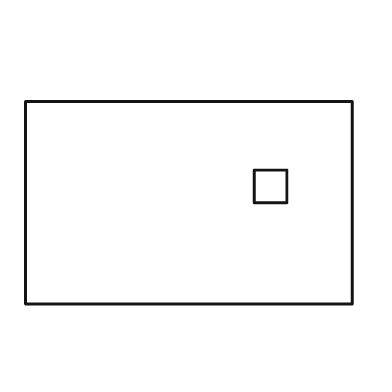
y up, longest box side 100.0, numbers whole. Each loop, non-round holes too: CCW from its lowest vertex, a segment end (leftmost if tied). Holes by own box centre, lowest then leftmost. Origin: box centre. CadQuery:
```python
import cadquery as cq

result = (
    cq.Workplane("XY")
    .moveTo(-50.0, -31.0)
    .lineTo(50.0, -31.0)
    .lineTo(50.0, 31.0)
    .lineTo(-50.0, 31.0)
    .close()
    .moveTo(20.0, 0.0)
    .lineTo(30.0, 0.0)
    .lineTo(30.0, 10.0)
    .lineTo(20.0, 10.0)
    .close()
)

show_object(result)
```